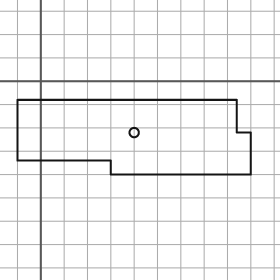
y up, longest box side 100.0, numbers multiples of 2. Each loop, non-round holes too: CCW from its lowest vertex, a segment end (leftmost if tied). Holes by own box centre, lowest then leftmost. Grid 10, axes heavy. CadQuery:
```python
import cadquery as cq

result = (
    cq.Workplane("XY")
    .moveTo(30.0, -40.0)
    .lineTo(90.0, -40.0)
    .lineTo(90.0, -22.0)
    .lineTo(84.0, -22.0)
    .lineTo(84.0, -8.0)
    .lineTo(-10.0, -8.0)
    .lineTo(-10.0, -34.0)
    .lineTo(30.0, -34.0)
    .close()
    .moveTo(40.0, -22.0)
    .circle(2.0)
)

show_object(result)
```